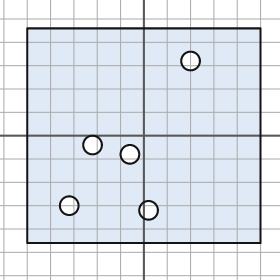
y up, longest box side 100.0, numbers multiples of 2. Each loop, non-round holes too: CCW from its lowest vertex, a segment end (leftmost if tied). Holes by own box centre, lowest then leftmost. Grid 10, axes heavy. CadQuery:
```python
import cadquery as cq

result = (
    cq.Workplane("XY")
    .moveTo(-50.0, -46.0)
    .lineTo(50.0, -46.0)
    .lineTo(50.0, 46.0)
    .lineTo(-50.0, 46.0)
    .close()
    .moveTo(2.0, -32.0)
    .circle(4.0)
    .moveTo(-32.0, -30.0)
    .circle(4.0)
    .moveTo(-6.0, -8.0)
    .circle(4.0)
    .moveTo(-22.0, -4.0)
    .circle(4.0)
    .moveTo(20.0, 32.0)
    .circle(4.0)
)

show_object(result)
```